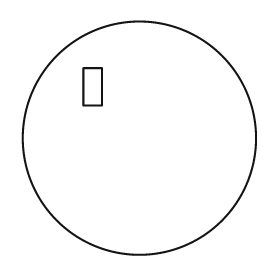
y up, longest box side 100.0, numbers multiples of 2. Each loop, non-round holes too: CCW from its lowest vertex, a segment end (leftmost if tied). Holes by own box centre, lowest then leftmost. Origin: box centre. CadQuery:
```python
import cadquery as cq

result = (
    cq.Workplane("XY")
    .moveTo(0.0, 0.0)
    .circle(50.0)
    .moveTo(-24.0, 14.0)
    .lineTo(-16.0, 14.0)
    .lineTo(-16.0, 30.0)
    .lineTo(-24.0, 30.0)
    .close()
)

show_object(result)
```